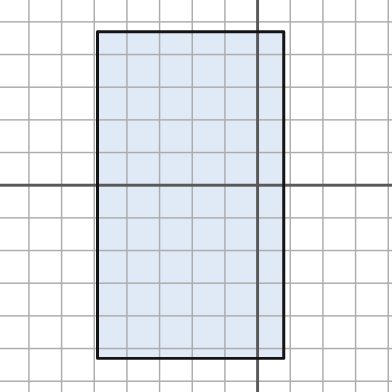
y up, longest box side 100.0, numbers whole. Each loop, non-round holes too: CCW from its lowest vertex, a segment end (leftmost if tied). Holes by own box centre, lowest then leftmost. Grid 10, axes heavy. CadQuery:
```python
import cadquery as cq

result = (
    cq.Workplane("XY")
    .moveTo(-49.0, -53.0)
    .lineTo(8.0, -53.0)
    .lineTo(8.0, 47.0)
    .lineTo(-49.0, 47.0)
    .close()
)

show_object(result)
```